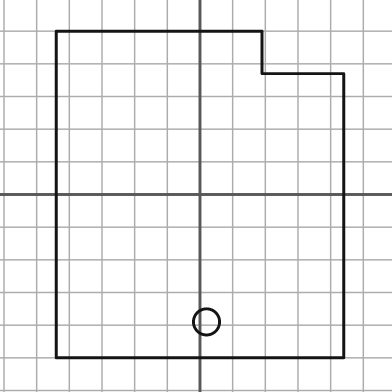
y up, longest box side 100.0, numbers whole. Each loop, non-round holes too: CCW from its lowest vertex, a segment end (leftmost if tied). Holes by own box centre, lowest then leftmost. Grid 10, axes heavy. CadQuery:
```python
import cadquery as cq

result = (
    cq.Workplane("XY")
    .moveTo(-44.0, -50.0)
    .lineTo(44.0, -50.0)
    .lineTo(44.0, 37.0)
    .lineTo(19.0, 37.0)
    .lineTo(19.0, 50.0)
    .lineTo(-44.0, 50.0)
    .close()
    .moveTo(2.0, -39.0)
    .circle(4.0)
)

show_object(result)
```